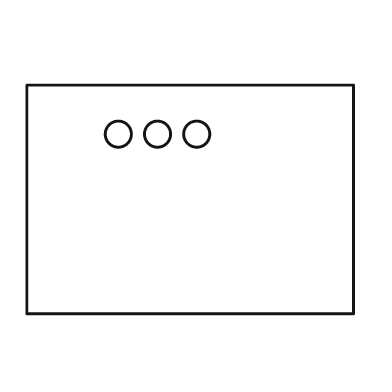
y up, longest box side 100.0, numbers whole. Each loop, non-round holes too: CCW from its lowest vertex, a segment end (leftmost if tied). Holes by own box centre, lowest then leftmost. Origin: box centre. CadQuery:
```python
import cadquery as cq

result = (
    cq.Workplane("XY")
    .moveTo(-50.0, -35.0)
    .lineTo(50.0, -35.0)
    .lineTo(50.0, 35.0)
    .lineTo(-50.0, 35.0)
    .close()
    .moveTo(-22.0, 20.0)
    .circle(4.0)
    .moveTo(-10.0, 20.0)
    .circle(4.0)
    .moveTo(2.0, 20.0)
    .circle(4.0)
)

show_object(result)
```